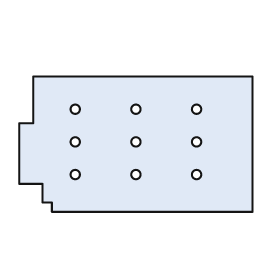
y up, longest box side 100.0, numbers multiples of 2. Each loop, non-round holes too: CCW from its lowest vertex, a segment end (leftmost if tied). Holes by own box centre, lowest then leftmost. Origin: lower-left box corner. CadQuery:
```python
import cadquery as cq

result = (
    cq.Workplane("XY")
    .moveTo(14.0, 0.0)
    .lineTo(100.0, 0.0)
    .lineTo(100.0, 58.0)
    .lineTo(6.0, 58.0)
    .lineTo(6.0, 38.0)
    .lineTo(0.0, 38.0)
    .lineTo(0.0, 12.0)
    .lineTo(10.0, 12.0)
    .lineTo(10.0, 4.0)
    .lineTo(14.0, 4.0)
    .close()
    .moveTo(24.0, 16.0)
    .circle(2.0)
    .moveTo(50.0, 16.0)
    .circle(2.0)
    .moveTo(76.0, 16.0)
    .circle(2.0)
    .moveTo(24.0, 30.0)
    .circle(2.0)
    .moveTo(50.0, 30.0)
    .circle(2.0)
    .moveTo(76.0, 30.0)
    .circle(2.0)
    .moveTo(24.0, 44.0)
    .circle(2.0)
    .moveTo(50.0, 44.0)
    .circle(2.0)
    .moveTo(76.0, 44.0)
    .circle(2.0)
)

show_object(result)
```